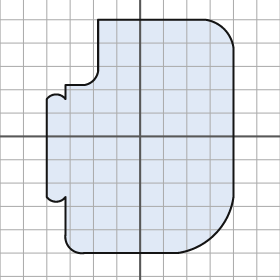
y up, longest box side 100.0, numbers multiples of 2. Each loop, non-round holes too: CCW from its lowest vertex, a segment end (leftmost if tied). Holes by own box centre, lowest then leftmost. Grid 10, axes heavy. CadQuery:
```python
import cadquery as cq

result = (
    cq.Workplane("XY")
    .moveTo(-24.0, -50.0)
    .lineTo(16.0, -50.0)
    .threePointArc((32.0, -42.0), (40.0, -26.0))
    .lineTo(40.0, 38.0)
    .threePointArc((36.0, 46.0), (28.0, 50.0))
    .lineTo(-18.0, 50.0)
    .lineTo(-18.0, 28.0)
    .threePointArc((-20.0, 24.0), (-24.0, 22.0))
    .lineTo(-32.0, 22.0)
    .lineTo(-32.0, 16.0)
    .threePointArc((-36.0, 18.0), (-40.0, 16.0))
    .lineTo(-40.0, -26.0)
    .threePointArc((-36.0, -28.0), (-32.0, -26.0))
    .lineTo(-32.0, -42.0)
    .threePointArc((-30.0, -48.0), (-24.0, -50.0))
    .close()
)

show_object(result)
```